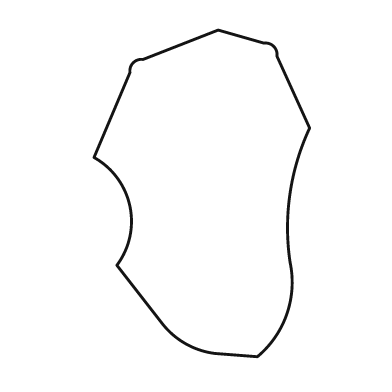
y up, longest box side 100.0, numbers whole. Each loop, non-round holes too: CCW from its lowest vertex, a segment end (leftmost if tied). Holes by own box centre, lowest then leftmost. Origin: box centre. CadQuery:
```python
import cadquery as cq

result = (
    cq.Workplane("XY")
    .moveTo(17.0, -50.0)
    .threePointArc((26.0, -37.0), (27.0, -21.0))
    .threePointArc((27.0, 0.0), (33.0, 20.0))
    .lineTo(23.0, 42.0)
    .threePointArc((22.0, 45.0), (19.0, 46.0))
    .lineTo(5.0, 50.0)
    .lineTo(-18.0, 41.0)
    .threePointArc((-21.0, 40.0), (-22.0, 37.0))
    .lineTo(-33.0, 11.0)
    .threePointArc((-22.0, -4.0), (-26.0, -22.0))
    .lineTo(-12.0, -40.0)
    .threePointArc((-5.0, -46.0), (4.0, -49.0))
    .close()
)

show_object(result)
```